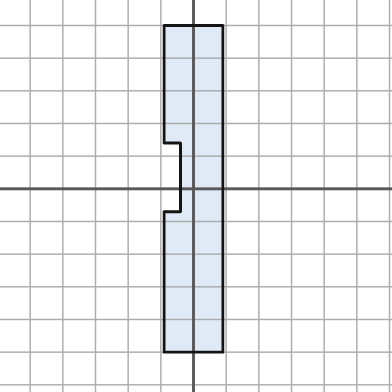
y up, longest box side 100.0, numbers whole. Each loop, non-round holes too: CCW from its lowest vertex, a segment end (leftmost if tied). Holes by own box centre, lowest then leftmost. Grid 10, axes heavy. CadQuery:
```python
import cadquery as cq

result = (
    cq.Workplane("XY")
    .moveTo(-9.0, -50.0)
    .lineTo(9.0, -50.0)
    .lineTo(9.0, 50.0)
    .lineTo(-9.0, 50.0)
    .lineTo(-9.0, 14.0)
    .lineTo(-4.0, 14.0)
    .lineTo(-4.0, -7.0)
    .lineTo(-9.0, -7.0)
    .close()
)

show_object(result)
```